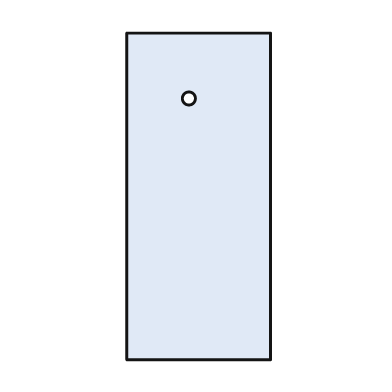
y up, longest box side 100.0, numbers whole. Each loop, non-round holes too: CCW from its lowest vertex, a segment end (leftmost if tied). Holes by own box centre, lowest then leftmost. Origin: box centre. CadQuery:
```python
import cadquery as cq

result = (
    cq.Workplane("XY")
    .moveTo(-22.0, -50.0)
    .lineTo(22.0, -50.0)
    .lineTo(22.0, 50.0)
    .lineTo(-22.0, 50.0)
    .close()
    .moveTo(-3.0, 30.0)
    .circle(2.0)
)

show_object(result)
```